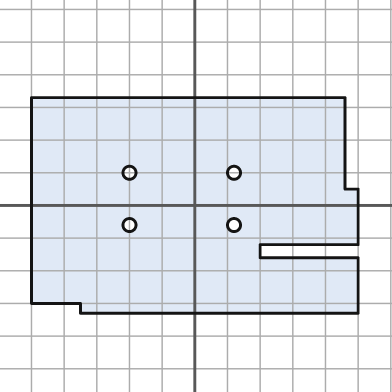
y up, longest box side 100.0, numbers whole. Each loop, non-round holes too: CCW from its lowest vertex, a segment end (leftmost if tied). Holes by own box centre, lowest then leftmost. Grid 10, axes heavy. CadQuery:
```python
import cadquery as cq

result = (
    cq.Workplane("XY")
    .moveTo(-35.0, -33.0)
    .lineTo(50.0, -33.0)
    .lineTo(50.0, -16.0)
    .lineTo(20.0, -16.0)
    .lineTo(20.0, -12.0)
    .lineTo(50.0, -12.0)
    .lineTo(50.0, 5.0)
    .lineTo(46.0, 5.0)
    .lineTo(46.0, 33.0)
    .lineTo(-50.0, 33.0)
    .lineTo(-50.0, -30.0)
    .lineTo(-35.0, -30.0)
    .close()
    .moveTo(-20.0, -6.0)
    .circle(2.0)
    .moveTo(12.0, -6.0)
    .circle(2.0)
    .moveTo(-20.0, 10.0)
    .circle(2.0)
    .moveTo(12.0, 10.0)
    .circle(2.0)
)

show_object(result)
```